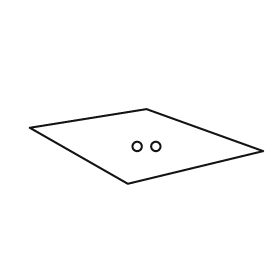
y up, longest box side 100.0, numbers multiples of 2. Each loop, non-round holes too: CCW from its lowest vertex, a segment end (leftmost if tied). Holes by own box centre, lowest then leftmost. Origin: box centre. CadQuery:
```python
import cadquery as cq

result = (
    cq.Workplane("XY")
    .moveTo(-8.0, -16.0)
    .lineTo(50.0, -2.0)
    .lineTo(0.0, 16.0)
    .lineTo(-50.0, 8.0)
    .close()
    .moveTo(-4.0, 0.0)
    .circle(2.0)
    .moveTo(4.0, 0.0)
    .circle(2.0)
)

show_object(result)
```